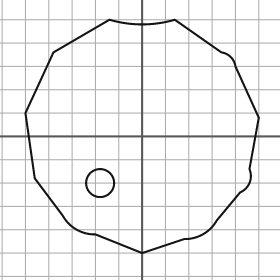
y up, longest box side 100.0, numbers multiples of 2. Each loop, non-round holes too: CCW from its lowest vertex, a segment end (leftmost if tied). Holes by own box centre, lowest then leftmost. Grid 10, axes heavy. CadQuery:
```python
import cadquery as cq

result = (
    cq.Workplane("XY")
    .moveTo(0.0, -50.0)
    .lineTo(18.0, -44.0)
    .threePointArc((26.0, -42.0), (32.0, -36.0))
    .lineTo(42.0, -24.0)
    .threePointArc((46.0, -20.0), (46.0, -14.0))
    .lineTo(50.0, 8.0)
    .lineTo(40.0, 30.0)
    .threePointArc((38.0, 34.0), (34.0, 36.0))
    .lineTo(14.0, 50.0)
    .threePointArc((0.0, 48.0), (-14.0, 50.0))
    .lineTo(-38.0, 36.0)
    .lineTo(-50.0, 10.0)
    .lineTo(-46.0, -18.0)
    .lineTo(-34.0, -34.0)
    .threePointArc((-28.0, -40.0), (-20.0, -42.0))
    .close()
    .moveTo(-18.0, -20.0)
    .circle(6.0)
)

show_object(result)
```